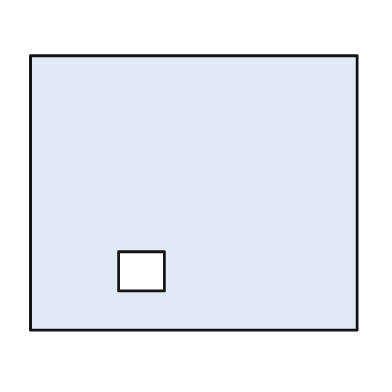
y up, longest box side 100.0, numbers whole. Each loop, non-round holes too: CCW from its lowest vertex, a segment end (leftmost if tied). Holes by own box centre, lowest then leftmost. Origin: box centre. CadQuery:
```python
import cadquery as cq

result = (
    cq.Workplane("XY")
    .moveTo(-50.0, -42.0)
    .lineTo(50.0, -42.0)
    .lineTo(50.0, 42.0)
    .lineTo(-50.0, 42.0)
    .close()
    .moveTo(-23.0, -30.0)
    .lineTo(-9.0, -30.0)
    .lineTo(-9.0, -18.0)
    .lineTo(-23.0, -18.0)
    .close()
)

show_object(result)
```